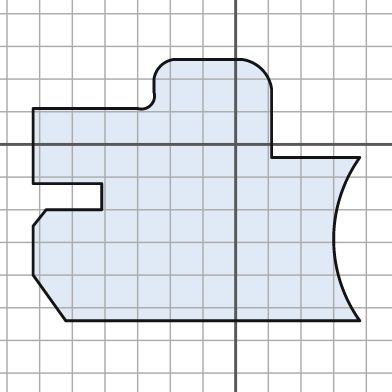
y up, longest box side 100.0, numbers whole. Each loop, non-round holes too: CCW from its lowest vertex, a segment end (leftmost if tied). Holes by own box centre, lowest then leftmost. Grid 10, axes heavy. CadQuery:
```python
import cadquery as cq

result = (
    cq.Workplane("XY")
    .moveTo(-52.0, -54.0)
    .lineTo(38.0, -54.0)
    .threePointArc((30.0, -29.0), (38.0, -4.0))
    .lineTo(11.0, -4.0)
    .lineTo(11.0, 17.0)
    .threePointArc((8.0, 23.0), (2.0, 26.0))
    .lineTo(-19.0, 26.0)
    .threePointArc((-23.0, 24.0), (-25.0, 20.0))
    .lineTo(-25.0, 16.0)
    .threePointArc((-26.0, 12.0), (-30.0, 11.0))
    .lineTo(-62.0, 11.0)
    .lineTo(-62.0, -12.0)
    .lineTo(-41.0, -12.0)
    .lineTo(-41.0, -20.0)
    .lineTo(-58.0, -20.0)
    .lineTo(-62.0, -25.0)
    .lineTo(-62.0, -40.0)
    .close()
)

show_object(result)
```